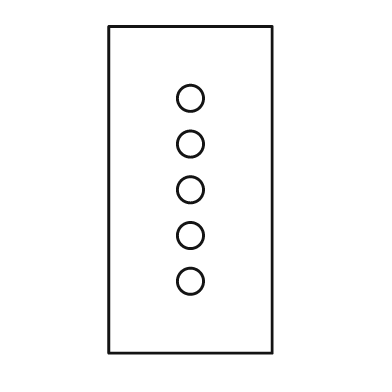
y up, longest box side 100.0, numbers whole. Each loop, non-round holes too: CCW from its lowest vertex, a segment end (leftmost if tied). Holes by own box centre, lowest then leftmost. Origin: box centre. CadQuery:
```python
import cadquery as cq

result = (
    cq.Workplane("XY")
    .moveTo(-25.0, -50.0)
    .lineTo(25.0, -50.0)
    .lineTo(25.0, 50.0)
    .lineTo(-25.0, 50.0)
    .close()
    .moveTo(0.0, -28.0)
    .circle(4.0)
    .moveTo(0.0, -14.0)
    .circle(4.0)
    .moveTo(0.0, 0.0)
    .circle(4.0)
    .moveTo(0.0, 14.0)
    .circle(4.0)
    .moveTo(0.0, 28.0)
    .circle(4.0)
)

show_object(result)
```